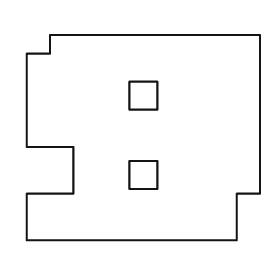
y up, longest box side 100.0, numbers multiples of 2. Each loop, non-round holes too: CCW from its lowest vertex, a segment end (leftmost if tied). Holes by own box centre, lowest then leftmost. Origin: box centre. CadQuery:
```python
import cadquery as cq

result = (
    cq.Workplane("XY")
    .moveTo(-50.0, -44.0)
    .lineTo(40.0, -44.0)
    .lineTo(40.0, -24.0)
    .lineTo(50.0, -24.0)
    .lineTo(50.0, 44.0)
    .lineTo(-40.0, 44.0)
    .lineTo(-40.0, 36.0)
    .lineTo(-50.0, 36.0)
    .lineTo(-50.0, -4.0)
    .lineTo(-30.0, -4.0)
    .lineTo(-30.0, -24.0)
    .lineTo(-50.0, -24.0)
    .close()
    .moveTo(-6.0, -22.0)
    .lineTo(6.0, -22.0)
    .lineTo(6.0, -10.0)
    .lineTo(-6.0, -10.0)
    .close()
    .moveTo(-6.0, 12.0)
    .lineTo(6.0, 12.0)
    .lineTo(6.0, 24.0)
    .lineTo(-6.0, 24.0)
    .close()
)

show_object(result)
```